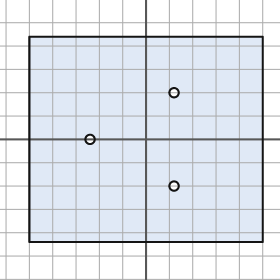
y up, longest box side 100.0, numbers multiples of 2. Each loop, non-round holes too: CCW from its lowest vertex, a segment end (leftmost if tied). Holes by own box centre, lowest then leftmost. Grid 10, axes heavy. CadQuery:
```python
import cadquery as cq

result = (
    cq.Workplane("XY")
    .moveTo(-50.0, -44.0)
    .lineTo(50.0, -44.0)
    .lineTo(50.0, 44.0)
    .lineTo(-50.0, 44.0)
    .close()
    .moveTo(12.0, -20.0)
    .circle(2.0)
    .moveTo(-24.0, 0.0)
    .circle(2.0)
    .moveTo(12.0, 20.0)
    .circle(2.0)
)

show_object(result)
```